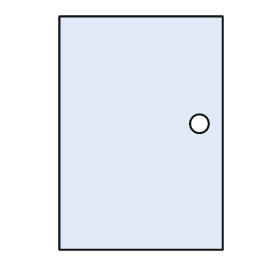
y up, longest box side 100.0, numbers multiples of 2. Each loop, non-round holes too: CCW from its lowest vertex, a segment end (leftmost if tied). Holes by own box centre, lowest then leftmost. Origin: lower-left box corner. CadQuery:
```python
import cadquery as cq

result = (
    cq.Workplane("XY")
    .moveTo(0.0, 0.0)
    .lineTo(70.0, 0.0)
    .lineTo(70.0, 100.0)
    .lineTo(0.0, 100.0)
    .close()
    .moveTo(60.0, 54.0)
    .circle(4.0)
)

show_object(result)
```